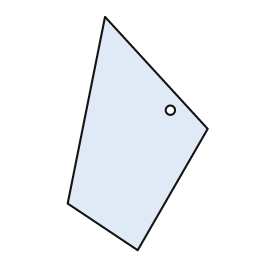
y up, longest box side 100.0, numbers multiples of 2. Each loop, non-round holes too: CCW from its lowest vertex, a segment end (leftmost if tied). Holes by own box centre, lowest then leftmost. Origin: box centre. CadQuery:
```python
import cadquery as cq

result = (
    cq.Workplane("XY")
    .moveTo(0.0, -50.0)
    .lineTo(30.0, 2.0)
    .lineTo(-14.0, 50.0)
    .lineTo(-30.0, -30.0)
    .close()
    .moveTo(14.0, 10.0)
    .circle(2.0)
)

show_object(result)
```